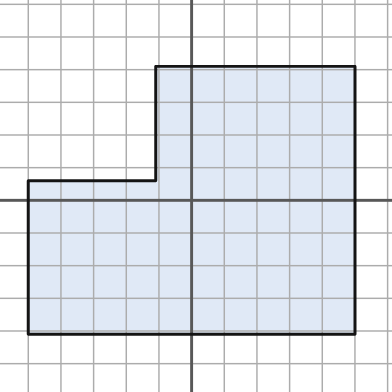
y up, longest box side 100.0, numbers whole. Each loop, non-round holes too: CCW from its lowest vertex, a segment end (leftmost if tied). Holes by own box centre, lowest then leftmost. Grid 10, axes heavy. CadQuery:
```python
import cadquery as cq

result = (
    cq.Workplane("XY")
    .moveTo(-50.0, -41.0)
    .lineTo(50.0, -41.0)
    .lineTo(50.0, 41.0)
    .lineTo(-11.0, 41.0)
    .lineTo(-11.0, 6.0)
    .lineTo(-50.0, 6.0)
    .close()
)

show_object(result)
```